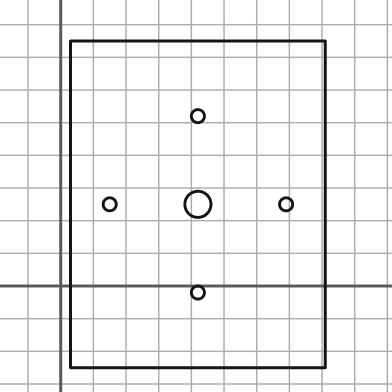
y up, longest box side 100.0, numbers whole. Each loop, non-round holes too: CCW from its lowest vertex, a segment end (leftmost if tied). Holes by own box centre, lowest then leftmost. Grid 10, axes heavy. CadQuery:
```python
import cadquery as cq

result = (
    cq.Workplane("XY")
    .moveTo(3.0, -25.0)
    .lineTo(81.0, -25.0)
    .lineTo(81.0, 75.0)
    .lineTo(3.0, 75.0)
    .close()
    .moveTo(42.0, -2.0)
    .circle(2.0)
    .moveTo(15.0, 25.0)
    .circle(2.0)
    .moveTo(42.0, 25.0)
    .circle(4.0)
    .moveTo(69.0, 25.0)
    .circle(2.0)
    .moveTo(42.0, 52.0)
    .circle(2.0)
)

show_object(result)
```